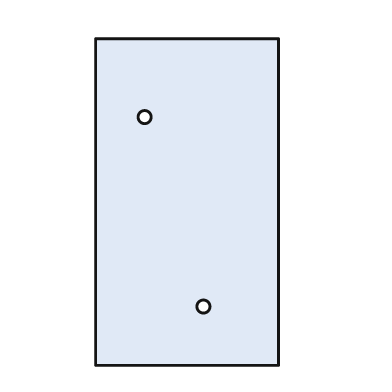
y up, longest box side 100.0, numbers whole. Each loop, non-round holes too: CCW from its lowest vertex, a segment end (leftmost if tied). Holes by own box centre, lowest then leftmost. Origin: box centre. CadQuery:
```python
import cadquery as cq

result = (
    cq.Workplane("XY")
    .moveTo(-28.0, -50.0)
    .lineTo(28.0, -50.0)
    .lineTo(28.0, 50.0)
    .lineTo(-28.0, 50.0)
    .close()
    .moveTo(5.0, -32.0)
    .circle(2.0)
    .moveTo(-13.0, 26.0)
    .circle(2.0)
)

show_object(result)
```